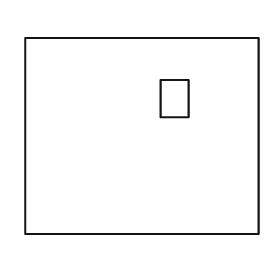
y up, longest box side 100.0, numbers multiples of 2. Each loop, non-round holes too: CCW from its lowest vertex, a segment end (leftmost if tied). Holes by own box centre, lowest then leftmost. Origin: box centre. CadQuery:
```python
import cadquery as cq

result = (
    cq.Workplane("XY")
    .moveTo(-50.0, -42.0)
    .lineTo(50.0, -42.0)
    .lineTo(50.0, 42.0)
    .lineTo(-50.0, 42.0)
    .close()
    .moveTo(8.0, 8.0)
    .lineTo(20.0, 8.0)
    .lineTo(20.0, 24.0)
    .lineTo(8.0, 24.0)
    .close()
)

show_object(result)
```